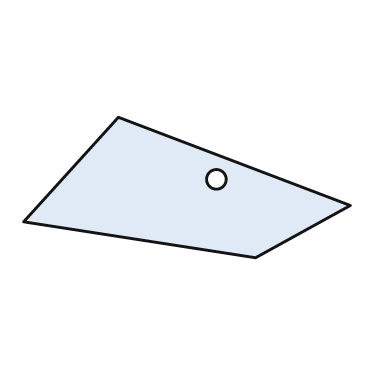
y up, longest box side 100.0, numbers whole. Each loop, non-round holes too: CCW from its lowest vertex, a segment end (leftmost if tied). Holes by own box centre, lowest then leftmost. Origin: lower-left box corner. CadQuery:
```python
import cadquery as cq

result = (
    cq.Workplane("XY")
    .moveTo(71.0, 0.0)
    .lineTo(100.0, 16.0)
    .lineTo(29.0, 43.0)
    .lineTo(0.0, 11.0)
    .close()
    .moveTo(59.0, 24.0)
    .circle(3.0)
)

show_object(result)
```